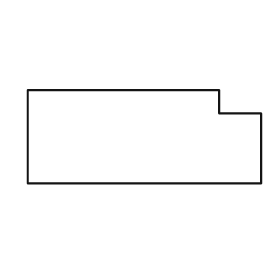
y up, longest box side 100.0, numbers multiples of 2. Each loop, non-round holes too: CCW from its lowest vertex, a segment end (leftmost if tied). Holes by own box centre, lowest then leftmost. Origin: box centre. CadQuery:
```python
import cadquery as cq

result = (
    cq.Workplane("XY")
    .moveTo(-50.0, -20.0)
    .lineTo(50.0, -20.0)
    .lineTo(50.0, 10.0)
    .lineTo(32.0, 10.0)
    .lineTo(32.0, 20.0)
    .lineTo(-50.0, 20.0)
    .close()
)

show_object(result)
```